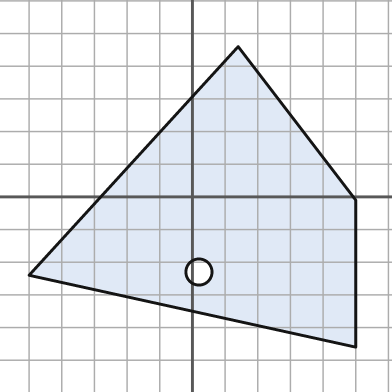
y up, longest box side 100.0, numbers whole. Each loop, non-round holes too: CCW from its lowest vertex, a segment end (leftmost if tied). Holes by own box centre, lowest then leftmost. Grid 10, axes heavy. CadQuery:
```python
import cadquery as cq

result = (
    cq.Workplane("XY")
    .moveTo(50.0, -46.0)
    .lineTo(50.0, -1.0)
    .lineTo(14.0, 46.0)
    .lineTo(-50.0, -24.0)
    .close()
    .moveTo(2.0, -23.0)
    .circle(4.0)
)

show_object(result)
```